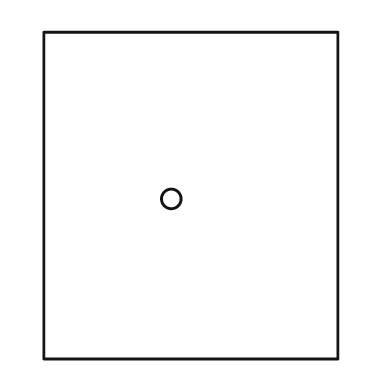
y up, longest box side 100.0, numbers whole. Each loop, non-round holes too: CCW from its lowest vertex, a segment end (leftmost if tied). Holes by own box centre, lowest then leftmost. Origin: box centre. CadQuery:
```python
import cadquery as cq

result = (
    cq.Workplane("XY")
    .moveTo(-45.0, -50.0)
    .lineTo(45.0, -50.0)
    .lineTo(45.0, 50.0)
    .lineTo(-45.0, 50.0)
    .close()
    .moveTo(-6.0, -1.0)
    .circle(3.0)
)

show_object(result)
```